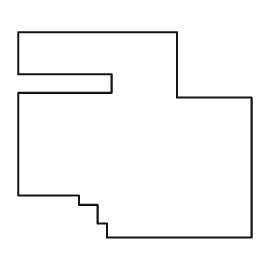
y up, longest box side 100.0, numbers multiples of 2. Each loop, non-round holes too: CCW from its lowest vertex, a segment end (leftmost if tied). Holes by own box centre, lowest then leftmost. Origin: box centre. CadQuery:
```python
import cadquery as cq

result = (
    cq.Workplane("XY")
    .moveTo(-12.0, -44.0)
    .lineTo(50.0, -44.0)
    .lineTo(50.0, 16.0)
    .lineTo(18.0, 16.0)
    .lineTo(18.0, 44.0)
    .lineTo(-50.0, 44.0)
    .lineTo(-50.0, 26.0)
    .lineTo(-10.0, 26.0)
    .lineTo(-10.0, 18.0)
    .lineTo(-50.0, 18.0)
    .lineTo(-50.0, -26.0)
    .lineTo(-24.0, -26.0)
    .lineTo(-24.0, -30.0)
    .lineTo(-16.0, -30.0)
    .lineTo(-16.0, -38.0)
    .lineTo(-12.0, -38.0)
    .close()
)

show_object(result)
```